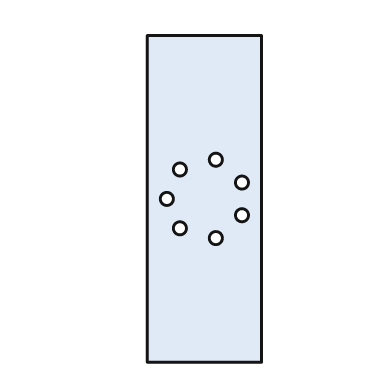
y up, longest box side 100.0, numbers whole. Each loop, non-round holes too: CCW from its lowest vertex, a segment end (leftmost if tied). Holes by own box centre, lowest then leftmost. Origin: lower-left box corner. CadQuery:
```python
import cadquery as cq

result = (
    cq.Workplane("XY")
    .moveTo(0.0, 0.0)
    .lineTo(35.0, 0.0)
    .lineTo(35.0, 100.0)
    .lineTo(0.0, 100.0)
    .close()
    .moveTo(21.0, 38.0)
    .circle(2.0)
    .moveTo(10.0, 41.0)
    .circle(2.0)
    .moveTo(29.0, 45.0)
    .circle(2.0)
    .moveTo(6.0, 50.0)
    .circle(2.0)
    .moveTo(29.0, 55.0)
    .circle(2.0)
    .moveTo(10.0, 59.0)
    .circle(2.0)
    .moveTo(21.0, 62.0)
    .circle(2.0)
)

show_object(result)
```